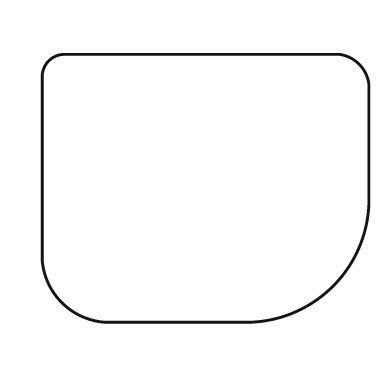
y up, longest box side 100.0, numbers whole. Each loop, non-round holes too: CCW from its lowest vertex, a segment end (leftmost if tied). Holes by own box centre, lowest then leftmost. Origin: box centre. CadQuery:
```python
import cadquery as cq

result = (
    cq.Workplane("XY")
    .moveTo(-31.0, -41.0)
    .lineTo(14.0, -41.0)
    .threePointArc((39.0, -30.0), (50.0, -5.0))
    .lineTo(50.0, 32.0)
    .threePointArc((47.0, 38.0), (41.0, 41.0))
    .lineTo(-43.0, 41.0)
    .threePointArc((-48.0, 39.0), (-50.0, 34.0))
    .lineTo(-50.0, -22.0)
    .threePointArc((-44.0, -35.0), (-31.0, -41.0))
    .close()
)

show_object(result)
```